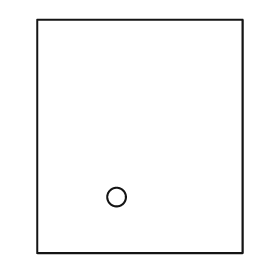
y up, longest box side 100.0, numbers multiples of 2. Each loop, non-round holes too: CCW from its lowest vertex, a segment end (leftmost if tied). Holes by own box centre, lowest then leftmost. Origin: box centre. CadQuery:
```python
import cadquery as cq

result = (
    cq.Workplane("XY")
    .moveTo(-44.0, -50.0)
    .lineTo(44.0, -50.0)
    .lineTo(44.0, 50.0)
    .lineTo(-44.0, 50.0)
    .close()
    .moveTo(-10.0, -26.0)
    .circle(4.0)
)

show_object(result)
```